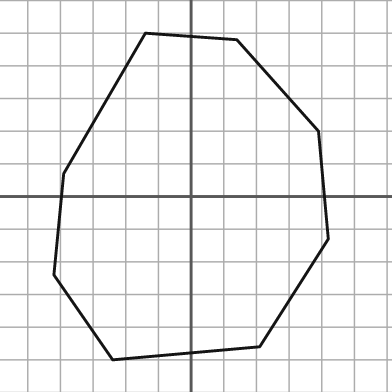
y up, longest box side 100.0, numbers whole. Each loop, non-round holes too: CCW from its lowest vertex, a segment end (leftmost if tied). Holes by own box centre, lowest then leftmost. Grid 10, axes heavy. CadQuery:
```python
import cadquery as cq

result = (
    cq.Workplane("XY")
    .moveTo(-24.0, -50.0)
    .lineTo(21.0, -46.0)
    .lineTo(42.0, -13.0)
    .lineTo(39.0, 20.0)
    .lineTo(14.0, 48.0)
    .lineTo(-14.0, 50.0)
    .lineTo(-39.0, 7.0)
    .lineTo(-42.0, -24.0)
    .close()
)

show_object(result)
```